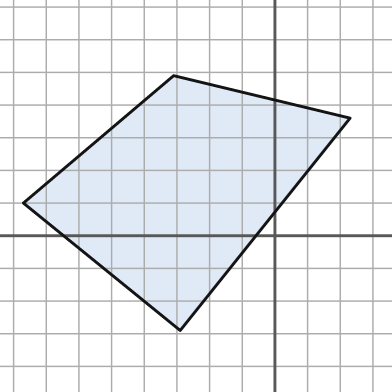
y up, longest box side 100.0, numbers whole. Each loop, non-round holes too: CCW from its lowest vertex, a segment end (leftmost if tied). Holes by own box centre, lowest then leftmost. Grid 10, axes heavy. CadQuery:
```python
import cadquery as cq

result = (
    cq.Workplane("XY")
    .moveTo(-29.0, -29.0)
    .lineTo(23.0, 36.0)
    .lineTo(-31.0, 49.0)
    .lineTo(-77.0, 10.0)
    .close()
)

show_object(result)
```